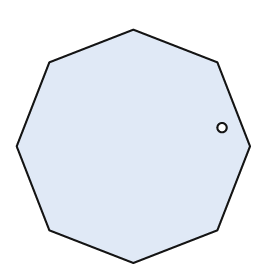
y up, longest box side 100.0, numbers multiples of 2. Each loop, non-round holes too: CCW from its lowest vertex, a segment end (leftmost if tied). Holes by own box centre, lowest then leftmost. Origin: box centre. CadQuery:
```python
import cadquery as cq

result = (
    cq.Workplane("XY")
    .moveTo(0.0, -50.0)
    .lineTo(36.0, -36.0)
    .lineTo(50.0, 0.0)
    .lineTo(36.0, 36.0)
    .lineTo(0.0, 50.0)
    .lineTo(-36.0, 36.0)
    .lineTo(-50.0, 0.0)
    .lineTo(-36.0, -36.0)
    .close()
    .moveTo(38.0, 8.0)
    .circle(2.0)
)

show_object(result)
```